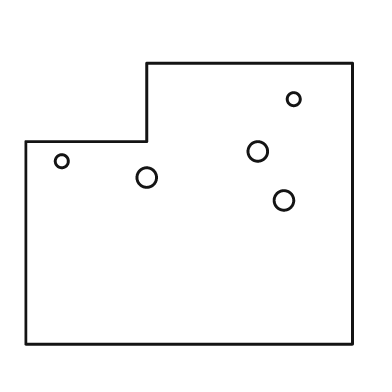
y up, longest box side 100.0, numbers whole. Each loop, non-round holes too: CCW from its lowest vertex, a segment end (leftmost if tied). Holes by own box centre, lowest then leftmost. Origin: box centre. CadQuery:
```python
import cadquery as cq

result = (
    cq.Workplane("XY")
    .moveTo(-50.0, -43.0)
    .lineTo(50.0, -43.0)
    .lineTo(50.0, 43.0)
    .lineTo(-13.0, 43.0)
    .lineTo(-13.0, 19.0)
    .lineTo(-50.0, 19.0)
    .close()
    .moveTo(29.0, 1.0)
    .circle(3.0)
    .moveTo(-13.0, 8.0)
    .circle(3.0)
    .moveTo(-39.0, 13.0)
    .circle(2.0)
    .moveTo(21.0, 16.0)
    .circle(3.0)
    .moveTo(32.0, 32.0)
    .circle(2.0)
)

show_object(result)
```